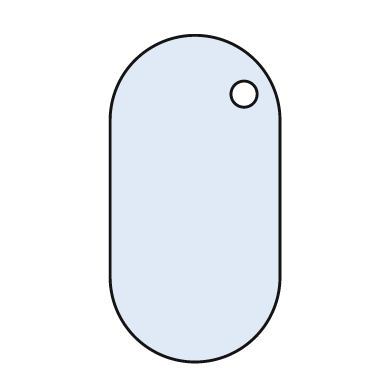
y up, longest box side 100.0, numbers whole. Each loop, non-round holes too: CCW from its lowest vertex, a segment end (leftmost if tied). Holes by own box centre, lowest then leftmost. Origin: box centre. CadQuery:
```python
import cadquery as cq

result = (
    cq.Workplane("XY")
    .moveTo(-26.0, -24.0)
    .threePointArc((0.0, -50.0), (26.0, -24.0))
    .lineTo(26.0, 24.0)
    .threePointArc((0.0, 50.0), (-26.0, 24.0))
    .close()
    .moveTo(15.0, 32.0)
    .circle(4.0)
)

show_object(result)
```